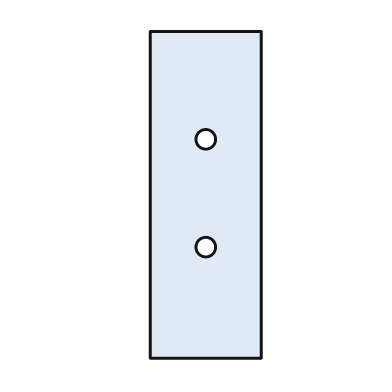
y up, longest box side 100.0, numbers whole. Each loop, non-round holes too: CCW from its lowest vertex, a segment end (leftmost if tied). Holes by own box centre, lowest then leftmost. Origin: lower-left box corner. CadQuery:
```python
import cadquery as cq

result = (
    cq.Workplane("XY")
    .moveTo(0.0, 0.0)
    .lineTo(34.0, 0.0)
    .lineTo(34.0, 100.0)
    .lineTo(0.0, 100.0)
    .close()
    .moveTo(17.0, 34.0)
    .circle(3.0)
    .moveTo(17.0, 67.0)
    .circle(3.0)
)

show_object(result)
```